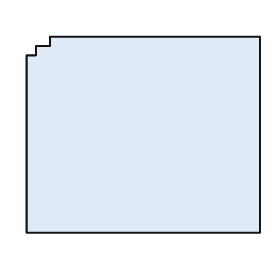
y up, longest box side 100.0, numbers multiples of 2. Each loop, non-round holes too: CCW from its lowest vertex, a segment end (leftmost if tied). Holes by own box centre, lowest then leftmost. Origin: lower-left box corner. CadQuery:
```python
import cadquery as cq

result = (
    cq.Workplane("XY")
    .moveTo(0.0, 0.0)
    .lineTo(100.0, 0.0)
    .lineTo(100.0, 84.0)
    .lineTo(10.0, 84.0)
    .lineTo(10.0, 80.0)
    .lineTo(4.0, 80.0)
    .lineTo(4.0, 76.0)
    .lineTo(0.0, 76.0)
    .close()
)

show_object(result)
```